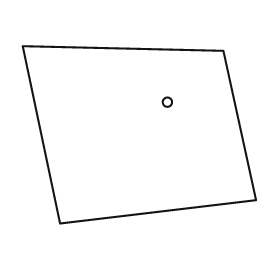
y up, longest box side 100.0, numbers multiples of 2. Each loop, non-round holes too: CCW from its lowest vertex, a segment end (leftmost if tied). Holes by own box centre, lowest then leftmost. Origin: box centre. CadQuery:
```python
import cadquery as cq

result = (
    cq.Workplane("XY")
    .moveTo(-34.0, -38.0)
    .lineTo(50.0, -28.0)
    .lineTo(36.0, 36.0)
    .lineTo(-50.0, 38.0)
    .close()
    .moveTo(12.0, 14.0)
    .circle(2.0)
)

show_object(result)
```